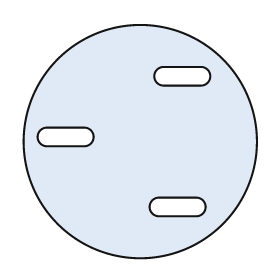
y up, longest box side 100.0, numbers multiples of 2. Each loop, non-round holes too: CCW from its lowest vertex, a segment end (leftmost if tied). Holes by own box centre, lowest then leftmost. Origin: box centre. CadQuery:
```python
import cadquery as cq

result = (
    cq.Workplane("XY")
    .moveTo(0.0, 0.0)
    .circle(50.0)
    .moveTo(8.0, -32.0)
    .lineTo(24.0, -32.0)
    .threePointArc((28.0, -28.0), (24.0, -24.0))
    .lineTo(8.0, -24.0)
    .threePointArc((4.0, -28.0), (8.0, -32.0))
    .close()
    .moveTo(-40.0, -2.0)
    .lineTo(-24.0, -2.0)
    .threePointArc((-20.0, 2.0), (-24.0, 6.0))
    .lineTo(-40.0, 6.0)
    .threePointArc((-44.0, 2.0), (-40.0, -2.0))
    .close()
    .moveTo(10.0, 24.0)
    .lineTo(26.0, 24.0)
    .threePointArc((30.0, 28.0), (26.0, 32.0))
    .lineTo(10.0, 32.0)
    .threePointArc((6.0, 28.0), (10.0, 24.0))
    .close()
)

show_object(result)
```